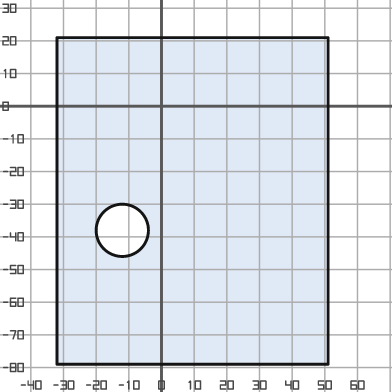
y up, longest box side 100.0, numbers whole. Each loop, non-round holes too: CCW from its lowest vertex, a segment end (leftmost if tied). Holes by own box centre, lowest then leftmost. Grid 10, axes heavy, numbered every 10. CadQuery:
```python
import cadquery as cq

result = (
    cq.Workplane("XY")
    .moveTo(-32.0, -79.0)
    .lineTo(51.0, -79.0)
    .lineTo(51.0, 21.0)
    .lineTo(-32.0, 21.0)
    .close()
    .moveTo(-12.0, -38.0)
    .circle(8.0)
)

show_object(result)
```